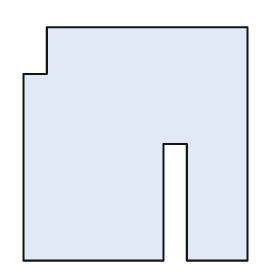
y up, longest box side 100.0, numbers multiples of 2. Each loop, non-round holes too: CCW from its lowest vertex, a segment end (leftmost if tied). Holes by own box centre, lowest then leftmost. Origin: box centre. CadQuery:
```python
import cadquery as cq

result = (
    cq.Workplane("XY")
    .moveTo(-48.0, -50.0)
    .lineTo(12.0, -50.0)
    .lineTo(12.0, 0.0)
    .lineTo(22.0, 0.0)
    .lineTo(22.0, -50.0)
    .lineTo(48.0, -50.0)
    .lineTo(48.0, 50.0)
    .lineTo(-38.0, 50.0)
    .lineTo(-38.0, 30.0)
    .lineTo(-48.0, 30.0)
    .close()
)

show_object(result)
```